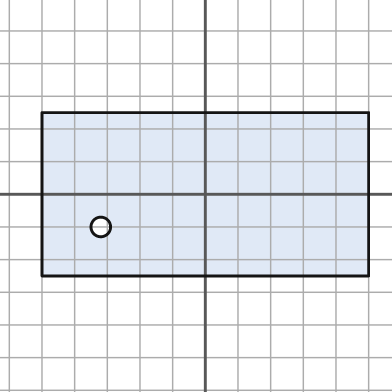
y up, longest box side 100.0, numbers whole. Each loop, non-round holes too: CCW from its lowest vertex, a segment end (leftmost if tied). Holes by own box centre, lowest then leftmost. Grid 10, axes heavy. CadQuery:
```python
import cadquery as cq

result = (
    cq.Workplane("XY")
    .moveTo(-50.0, -25.0)
    .lineTo(50.0, -25.0)
    .lineTo(50.0, 25.0)
    .lineTo(-50.0, 25.0)
    .close()
    .moveTo(-32.0, -10.0)
    .circle(3.0)
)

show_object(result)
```